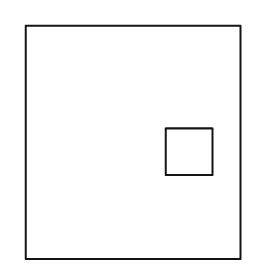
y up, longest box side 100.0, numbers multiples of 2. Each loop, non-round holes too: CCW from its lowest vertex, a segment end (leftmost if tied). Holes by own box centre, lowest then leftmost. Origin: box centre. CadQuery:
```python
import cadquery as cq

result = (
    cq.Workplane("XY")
    .moveTo(-46.0, -50.0)
    .lineTo(46.0, -50.0)
    .lineTo(46.0, 50.0)
    .lineTo(-46.0, 50.0)
    .close()
    .moveTo(14.0, -14.0)
    .lineTo(34.0, -14.0)
    .lineTo(34.0, 6.0)
    .lineTo(14.0, 6.0)
    .close()
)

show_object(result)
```